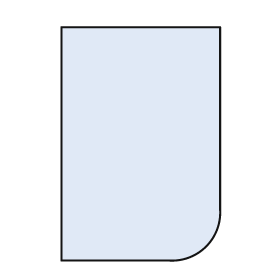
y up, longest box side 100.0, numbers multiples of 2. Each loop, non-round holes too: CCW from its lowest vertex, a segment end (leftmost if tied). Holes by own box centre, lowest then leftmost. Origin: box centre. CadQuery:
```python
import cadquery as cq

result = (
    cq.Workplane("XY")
    .moveTo(-34.0, -50.0)
    .lineTo(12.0, -50.0)
    .threePointArc((28.0, -44.0), (34.0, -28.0))
    .lineTo(34.0, 50.0)
    .lineTo(-34.0, 50.0)
    .close()
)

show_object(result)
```